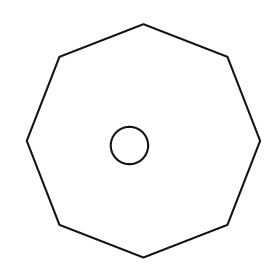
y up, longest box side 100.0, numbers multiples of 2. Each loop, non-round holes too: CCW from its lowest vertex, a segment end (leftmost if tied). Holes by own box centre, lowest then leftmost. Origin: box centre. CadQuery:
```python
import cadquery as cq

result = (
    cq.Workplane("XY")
    .moveTo(0.0, -50.0)
    .lineTo(36.0, -36.0)
    .lineTo(50.0, 0.0)
    .lineTo(36.0, 36.0)
    .lineTo(0.0, 50.0)
    .lineTo(-36.0, 36.0)
    .lineTo(-50.0, 0.0)
    .lineTo(-36.0, -36.0)
    .close()
    .moveTo(-6.0, -2.0)
    .circle(8.0)
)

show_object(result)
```